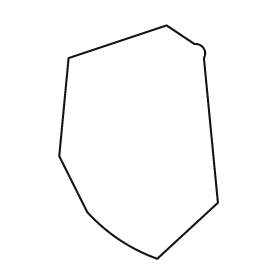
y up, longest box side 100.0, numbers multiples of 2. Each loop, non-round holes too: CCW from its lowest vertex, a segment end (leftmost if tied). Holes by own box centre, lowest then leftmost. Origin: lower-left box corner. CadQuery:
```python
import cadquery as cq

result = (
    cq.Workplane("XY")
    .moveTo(42.0, 0.0)
    .lineTo(68.0, 24.0)
    .lineTo(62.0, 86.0)
    .threePointArc((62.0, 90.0), (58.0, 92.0))
    .lineTo(46.0, 100.0)
    .lineTo(4.0, 86.0)
    .lineTo(0.0, 44.0)
    .lineTo(12.0, 20.0)
    .threePointArc((26.0, 8.0), (42.0, 0.0))
    .close()
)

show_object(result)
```